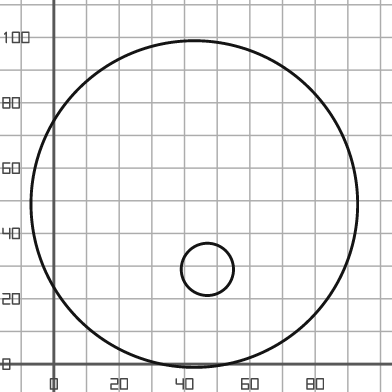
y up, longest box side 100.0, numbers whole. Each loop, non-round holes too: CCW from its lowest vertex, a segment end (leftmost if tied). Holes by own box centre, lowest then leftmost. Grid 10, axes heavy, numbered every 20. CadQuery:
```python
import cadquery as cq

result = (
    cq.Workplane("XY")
    .moveTo(43.0, 49.0)
    .circle(50.0)
    .moveTo(47.0, 29.0)
    .circle(8.0)
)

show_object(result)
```